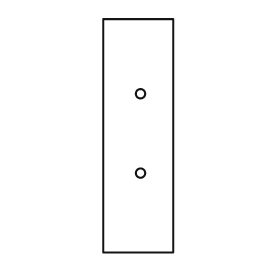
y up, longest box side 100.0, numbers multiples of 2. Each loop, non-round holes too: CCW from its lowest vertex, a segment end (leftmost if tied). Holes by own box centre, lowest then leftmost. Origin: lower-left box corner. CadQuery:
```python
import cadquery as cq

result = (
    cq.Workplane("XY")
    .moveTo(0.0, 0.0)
    .lineTo(30.0, 0.0)
    .lineTo(30.0, 100.0)
    .lineTo(0.0, 100.0)
    .close()
    .moveTo(16.0, 34.0)
    .circle(2.0)
    .moveTo(16.0, 68.0)
    .circle(2.0)
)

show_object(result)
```